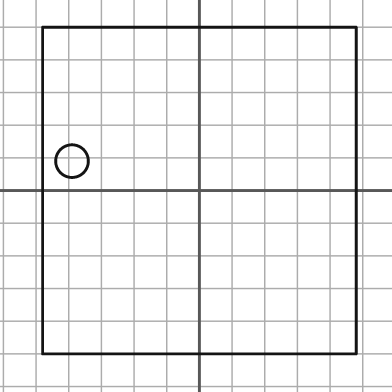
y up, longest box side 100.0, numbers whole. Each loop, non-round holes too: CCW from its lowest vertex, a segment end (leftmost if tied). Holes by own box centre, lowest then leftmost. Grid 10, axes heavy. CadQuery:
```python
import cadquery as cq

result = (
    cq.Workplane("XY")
    .moveTo(-48.0, -50.0)
    .lineTo(48.0, -50.0)
    .lineTo(48.0, 50.0)
    .lineTo(-48.0, 50.0)
    .close()
    .moveTo(-39.0, 9.0)
    .circle(5.0)
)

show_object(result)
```